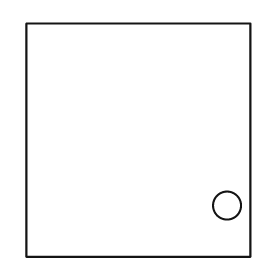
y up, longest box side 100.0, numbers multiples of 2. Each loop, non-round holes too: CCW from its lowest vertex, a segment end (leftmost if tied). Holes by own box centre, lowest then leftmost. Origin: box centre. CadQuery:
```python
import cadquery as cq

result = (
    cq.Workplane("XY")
    .moveTo(-48.0, -50.0)
    .lineTo(48.0, -50.0)
    .lineTo(48.0, 50.0)
    .lineTo(-48.0, 50.0)
    .close()
    .moveTo(38.0, -28.0)
    .circle(6.0)
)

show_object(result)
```